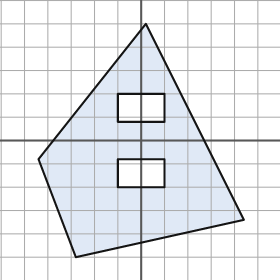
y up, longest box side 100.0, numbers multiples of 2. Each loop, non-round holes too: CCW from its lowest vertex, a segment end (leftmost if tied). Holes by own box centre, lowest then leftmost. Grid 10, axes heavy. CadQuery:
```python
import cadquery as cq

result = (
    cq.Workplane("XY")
    .moveTo(-28.0, -50.0)
    .lineTo(44.0, -34.0)
    .lineTo(2.0, 50.0)
    .lineTo(-44.0, -8.0)
    .close()
    .moveTo(-10.0, -20.0)
    .lineTo(10.0, -20.0)
    .lineTo(10.0, -8.0)
    .lineTo(-10.0, -8.0)
    .close()
    .moveTo(-10.0, 8.0)
    .lineTo(10.0, 8.0)
    .lineTo(10.0, 20.0)
    .lineTo(-10.0, 20.0)
    .close()
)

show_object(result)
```